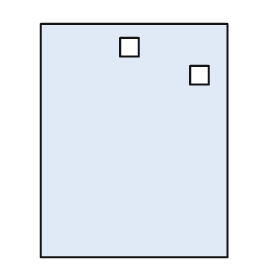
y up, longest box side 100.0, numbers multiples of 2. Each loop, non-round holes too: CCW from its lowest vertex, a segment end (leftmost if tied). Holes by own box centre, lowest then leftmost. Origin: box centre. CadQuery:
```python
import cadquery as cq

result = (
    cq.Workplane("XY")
    .moveTo(-40.0, -50.0)
    .lineTo(40.0, -50.0)
    .lineTo(40.0, 50.0)
    .lineTo(-40.0, 50.0)
    .close()
    .moveTo(24.0, 24.0)
    .lineTo(32.0, 24.0)
    .lineTo(32.0, 32.0)
    .lineTo(24.0, 32.0)
    .close()
    .moveTo(-6.0, 36.0)
    .lineTo(2.0, 36.0)
    .lineTo(2.0, 44.0)
    .lineTo(-6.0, 44.0)
    .close()
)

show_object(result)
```